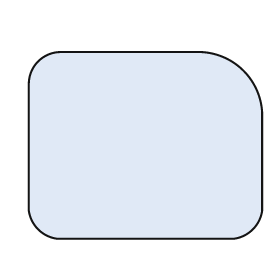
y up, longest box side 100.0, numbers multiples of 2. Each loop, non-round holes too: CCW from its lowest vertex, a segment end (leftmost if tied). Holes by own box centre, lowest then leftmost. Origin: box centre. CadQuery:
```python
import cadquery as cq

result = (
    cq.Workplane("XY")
    .moveTo(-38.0, -40.0)
    .lineTo(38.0, -40.0)
    .threePointArc((46.0, -36.0), (50.0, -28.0))
    .lineTo(50.0, 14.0)
    .threePointArc((42.0, 32.0), (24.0, 40.0))
    .lineTo(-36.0, 40.0)
    .threePointArc((-46.0, 36.0), (-50.0, 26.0))
    .lineTo(-50.0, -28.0)
    .threePointArc((-46.0, -36.0), (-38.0, -40.0))
    .close()
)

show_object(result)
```